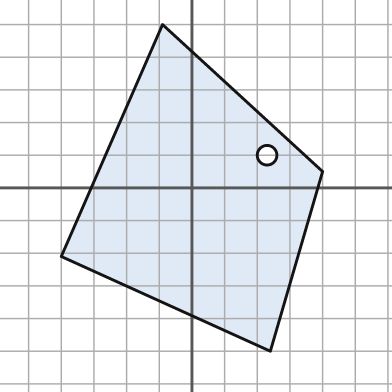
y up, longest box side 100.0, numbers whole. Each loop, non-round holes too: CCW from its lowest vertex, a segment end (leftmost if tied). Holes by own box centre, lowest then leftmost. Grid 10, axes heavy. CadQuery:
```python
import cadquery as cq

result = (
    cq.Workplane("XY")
    .moveTo(24.0, -50.0)
    .lineTo(40.0, 5.0)
    .lineTo(-9.0, 50.0)
    .lineTo(-40.0, -21.0)
    .close()
    .moveTo(23.0, 10.0)
    .circle(3.0)
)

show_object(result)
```